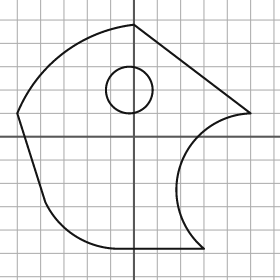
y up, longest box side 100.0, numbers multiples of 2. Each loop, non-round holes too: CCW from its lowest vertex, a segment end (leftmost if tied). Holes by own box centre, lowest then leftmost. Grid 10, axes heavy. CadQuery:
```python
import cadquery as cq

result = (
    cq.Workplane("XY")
    .moveTo(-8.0, -48.0)
    .lineTo(30.0, -48.0)
    .threePointArc((20.0, -12.0), (50.0, 10.0))
    .lineTo(0.0, 48.0)
    .threePointArc((-30.0, 36.0), (-50.0, 10.0))
    .lineTo(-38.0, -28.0)
    .threePointArc((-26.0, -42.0), (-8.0, -48.0))
    .close()
    .moveTo(-2.0, 20.0)
    .circle(10.0)
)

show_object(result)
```